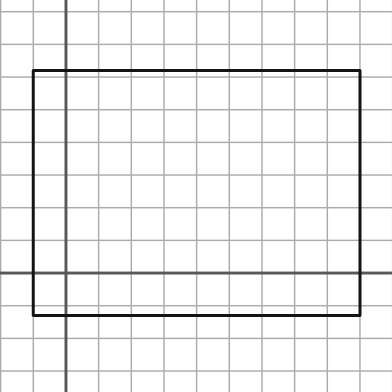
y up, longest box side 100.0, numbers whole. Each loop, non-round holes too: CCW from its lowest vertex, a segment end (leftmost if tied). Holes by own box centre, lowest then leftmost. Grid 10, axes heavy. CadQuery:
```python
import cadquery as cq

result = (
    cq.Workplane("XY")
    .moveTo(-10.0, -13.0)
    .lineTo(90.0, -13.0)
    .lineTo(90.0, 62.0)
    .lineTo(-10.0, 62.0)
    .close()
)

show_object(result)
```